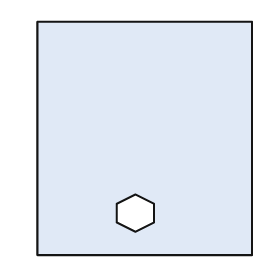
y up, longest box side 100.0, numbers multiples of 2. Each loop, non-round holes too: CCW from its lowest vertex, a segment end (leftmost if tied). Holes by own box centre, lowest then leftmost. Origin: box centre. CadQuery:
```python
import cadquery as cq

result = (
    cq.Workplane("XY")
    .moveTo(-46.0, -50.0)
    .lineTo(46.0, -50.0)
    .lineTo(46.0, 50.0)
    .lineTo(-46.0, 50.0)
    .close()
    .moveTo(-4.0, -40.0)
    .lineTo(4.0, -36.0)
    .lineTo(4.0, -28.0)
    .lineTo(-4.0, -24.0)
    .lineTo(-12.0, -28.0)
    .lineTo(-12.0, -36.0)
    .close()
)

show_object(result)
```